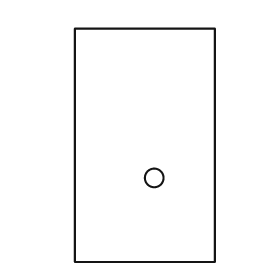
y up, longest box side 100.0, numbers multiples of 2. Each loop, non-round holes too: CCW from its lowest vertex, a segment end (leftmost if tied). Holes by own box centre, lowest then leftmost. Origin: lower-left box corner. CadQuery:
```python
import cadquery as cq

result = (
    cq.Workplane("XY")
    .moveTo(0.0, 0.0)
    .lineTo(60.0, 0.0)
    .lineTo(60.0, 100.0)
    .lineTo(0.0, 100.0)
    .close()
    .moveTo(34.0, 36.0)
    .circle(4.0)
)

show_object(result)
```